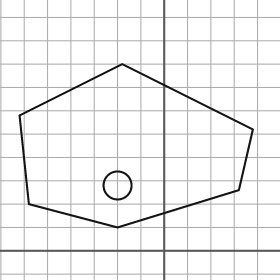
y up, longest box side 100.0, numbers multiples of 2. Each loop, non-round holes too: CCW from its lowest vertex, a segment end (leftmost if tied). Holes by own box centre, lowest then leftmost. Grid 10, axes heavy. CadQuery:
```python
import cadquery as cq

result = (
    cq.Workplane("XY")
    .moveTo(-20.0, 10.0)
    .lineTo(32.0, 26.0)
    .lineTo(38.0, 52.0)
    .lineTo(-18.0, 80.0)
    .lineTo(-62.0, 58.0)
    .lineTo(-58.0, 20.0)
    .close()
    .moveTo(-20.0, 28.0)
    .circle(6.0)
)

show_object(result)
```